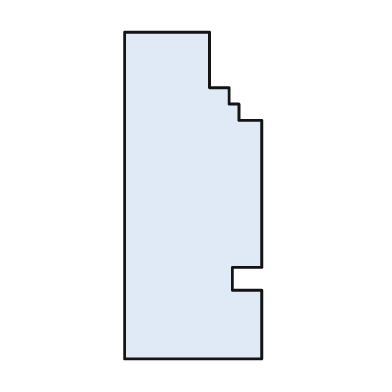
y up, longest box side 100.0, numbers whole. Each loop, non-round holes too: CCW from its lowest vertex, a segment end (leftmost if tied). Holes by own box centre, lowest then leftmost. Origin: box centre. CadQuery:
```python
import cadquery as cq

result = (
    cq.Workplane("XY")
    .moveTo(-21.0, -50.0)
    .lineTo(21.0, -50.0)
    .lineTo(21.0, -29.0)
    .lineTo(12.0, -29.0)
    .lineTo(12.0, -22.0)
    .lineTo(21.0, -22.0)
    .lineTo(21.0, 23.0)
    .lineTo(14.0, 23.0)
    .lineTo(14.0, 28.0)
    .lineTo(11.0, 28.0)
    .lineTo(11.0, 33.0)
    .lineTo(5.0, 33.0)
    .lineTo(5.0, 50.0)
    .lineTo(-21.0, 50.0)
    .close()
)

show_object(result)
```